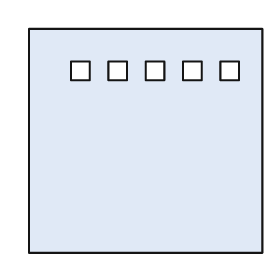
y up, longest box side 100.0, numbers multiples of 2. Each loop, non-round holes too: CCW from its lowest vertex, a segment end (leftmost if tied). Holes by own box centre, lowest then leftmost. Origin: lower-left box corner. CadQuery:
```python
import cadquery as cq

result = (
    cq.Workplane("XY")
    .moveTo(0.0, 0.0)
    .lineTo(100.0, 0.0)
    .lineTo(100.0, 96.0)
    .lineTo(0.0, 96.0)
    .close()
    .moveTo(18.0, 74.0)
    .lineTo(26.0, 74.0)
    .lineTo(26.0, 82.0)
    .lineTo(18.0, 82.0)
    .close()
    .moveTo(34.0, 74.0)
    .lineTo(42.0, 74.0)
    .lineTo(42.0, 82.0)
    .lineTo(34.0, 82.0)
    .close()
    .moveTo(50.0, 74.0)
    .lineTo(58.0, 74.0)
    .lineTo(58.0, 82.0)
    .lineTo(50.0, 82.0)
    .close()
    .moveTo(66.0, 74.0)
    .lineTo(74.0, 74.0)
    .lineTo(74.0, 82.0)
    .lineTo(66.0, 82.0)
    .close()
    .moveTo(82.0, 74.0)
    .lineTo(90.0, 74.0)
    .lineTo(90.0, 82.0)
    .lineTo(82.0, 82.0)
    .close()
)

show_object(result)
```